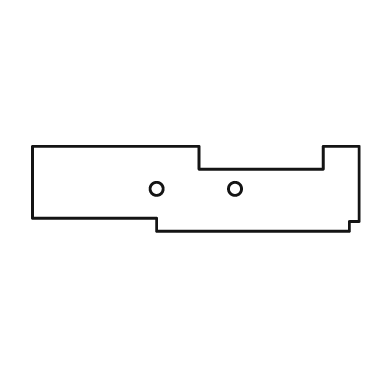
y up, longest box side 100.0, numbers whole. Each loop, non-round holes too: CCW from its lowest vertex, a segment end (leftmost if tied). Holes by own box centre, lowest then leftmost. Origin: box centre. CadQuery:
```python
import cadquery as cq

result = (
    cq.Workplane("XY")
    .moveTo(-12.0, -13.0)
    .lineTo(47.0, -13.0)
    .lineTo(47.0, -10.0)
    .lineTo(50.0, -10.0)
    .lineTo(50.0, 13.0)
    .lineTo(39.0, 13.0)
    .lineTo(39.0, 6.0)
    .lineTo(1.0, 6.0)
    .lineTo(1.0, 13.0)
    .lineTo(-50.0, 13.0)
    .lineTo(-50.0, -9.0)
    .lineTo(-12.0, -9.0)
    .close()
    .moveTo(-12.0, 0.0)
    .circle(2.0)
    .moveTo(12.0, 0.0)
    .circle(2.0)
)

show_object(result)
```